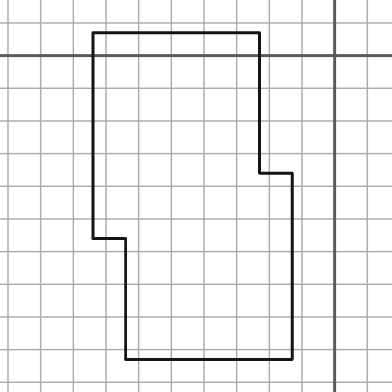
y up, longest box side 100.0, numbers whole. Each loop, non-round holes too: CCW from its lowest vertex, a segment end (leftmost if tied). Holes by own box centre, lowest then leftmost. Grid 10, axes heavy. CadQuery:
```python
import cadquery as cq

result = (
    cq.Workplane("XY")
    .moveTo(-64.0, -93.0)
    .lineTo(-13.0, -93.0)
    .lineTo(-13.0, -36.0)
    .lineTo(-23.0, -36.0)
    .lineTo(-23.0, 7.0)
    .lineTo(-74.0, 7.0)
    .lineTo(-74.0, -56.0)
    .lineTo(-64.0, -56.0)
    .close()
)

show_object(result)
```